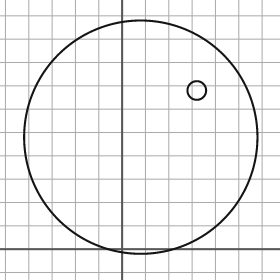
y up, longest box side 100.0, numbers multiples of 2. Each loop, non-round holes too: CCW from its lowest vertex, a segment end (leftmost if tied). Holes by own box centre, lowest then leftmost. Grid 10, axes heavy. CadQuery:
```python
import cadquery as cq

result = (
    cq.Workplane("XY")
    .moveTo(8.0, 48.0)
    .circle(50.0)
    .moveTo(32.0, 68.0)
    .circle(4.0)
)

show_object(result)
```